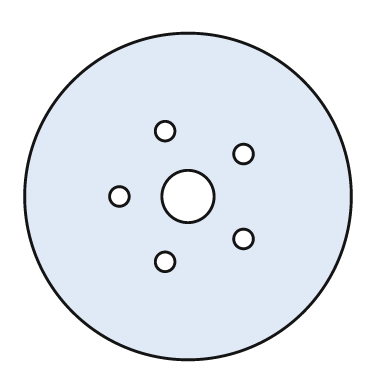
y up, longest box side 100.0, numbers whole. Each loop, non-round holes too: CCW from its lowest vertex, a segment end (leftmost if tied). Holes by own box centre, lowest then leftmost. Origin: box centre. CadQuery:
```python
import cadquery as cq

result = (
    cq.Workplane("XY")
    .moveTo(0.0, 0.0)
    .circle(50.0)
    .moveTo(-7.0, -20.0)
    .circle(3.0)
    .moveTo(17.0, -13.0)
    .circle(3.0)
    .moveTo(-21.0, 0.0)
    .circle(3.0)
    .moveTo(0.0, 0.0)
    .circle(8.0)
    .moveTo(17.0, 13.0)
    .circle(3.0)
    .moveTo(-7.0, 20.0)
    .circle(3.0)
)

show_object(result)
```